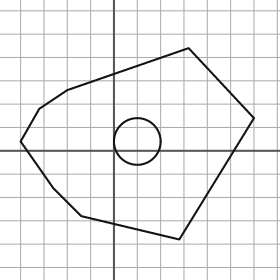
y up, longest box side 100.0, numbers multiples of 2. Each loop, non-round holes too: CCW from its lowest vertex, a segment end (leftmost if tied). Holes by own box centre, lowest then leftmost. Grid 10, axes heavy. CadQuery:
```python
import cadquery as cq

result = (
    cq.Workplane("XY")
    .moveTo(28.0, -38.0)
    .lineTo(60.0, 14.0)
    .lineTo(32.0, 44.0)
    .lineTo(-20.0, 26.0)
    .lineTo(-32.0, 18.0)
    .lineTo(-40.0, 4.0)
    .lineTo(-26.0, -16.0)
    .lineTo(-14.0, -28.0)
    .close()
    .moveTo(10.0, 4.0)
    .circle(10.0)
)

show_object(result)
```